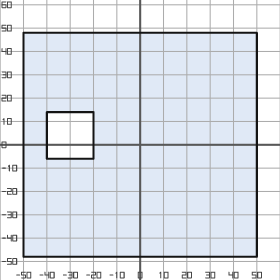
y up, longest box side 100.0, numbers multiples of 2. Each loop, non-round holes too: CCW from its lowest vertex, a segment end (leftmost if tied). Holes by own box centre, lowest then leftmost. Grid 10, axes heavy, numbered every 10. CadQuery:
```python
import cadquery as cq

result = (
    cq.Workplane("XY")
    .moveTo(-50.0, -48.0)
    .lineTo(50.0, -48.0)
    .lineTo(50.0, 48.0)
    .lineTo(-50.0, 48.0)
    .close()
    .moveTo(-40.0, -6.0)
    .lineTo(-20.0, -6.0)
    .lineTo(-20.0, 14.0)
    .lineTo(-40.0, 14.0)
    .close()
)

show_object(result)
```